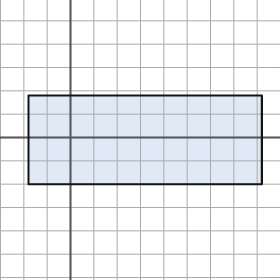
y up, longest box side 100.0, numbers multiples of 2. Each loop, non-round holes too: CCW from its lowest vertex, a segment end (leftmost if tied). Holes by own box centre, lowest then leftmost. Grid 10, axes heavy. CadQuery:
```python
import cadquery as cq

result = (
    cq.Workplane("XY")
    .moveTo(-18.0, -20.0)
    .lineTo(82.0, -20.0)
    .lineTo(82.0, 18.0)
    .lineTo(-18.0, 18.0)
    .close()
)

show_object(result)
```